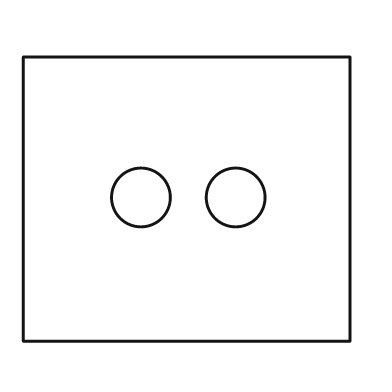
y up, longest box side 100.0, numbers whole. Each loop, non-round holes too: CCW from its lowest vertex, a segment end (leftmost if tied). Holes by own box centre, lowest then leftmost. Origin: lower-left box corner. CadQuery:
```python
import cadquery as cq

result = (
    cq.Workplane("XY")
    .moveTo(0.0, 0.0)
    .lineTo(100.0, 0.0)
    .lineTo(100.0, 87.0)
    .lineTo(0.0, 87.0)
    .close()
    .moveTo(36.0, 44.0)
    .circle(9.0)
    .moveTo(65.0, 44.0)
    .circle(9.0)
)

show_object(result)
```